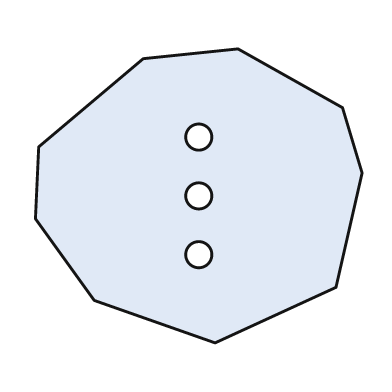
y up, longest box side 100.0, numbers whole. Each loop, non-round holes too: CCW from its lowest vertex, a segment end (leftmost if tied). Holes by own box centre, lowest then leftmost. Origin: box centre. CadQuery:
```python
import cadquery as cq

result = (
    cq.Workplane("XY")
    .moveTo(5.0, -45.0)
    .lineTo(42.0, -28.0)
    .lineTo(50.0, 7.0)
    .lineTo(44.0, 27.0)
    .lineTo(12.0, 45.0)
    .lineTo(-17.0, 42.0)
    .lineTo(-49.0, 15.0)
    .lineTo(-50.0, -7.0)
    .lineTo(-32.0, -32.0)
    .close()
    .moveTo(0.0, -18.0)
    .circle(4.0)
    .moveTo(0.0, 0.0)
    .circle(4.0)
    .moveTo(0.0, 18.0)
    .circle(4.0)
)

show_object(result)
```